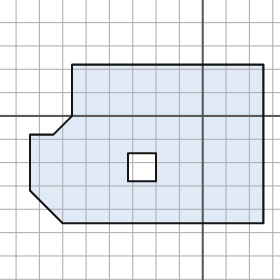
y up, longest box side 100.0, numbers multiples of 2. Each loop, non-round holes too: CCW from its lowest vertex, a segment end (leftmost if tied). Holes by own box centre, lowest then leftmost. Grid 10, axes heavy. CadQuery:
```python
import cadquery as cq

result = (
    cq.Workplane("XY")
    .moveTo(-60.0, -46.0)
    .lineTo(26.0, -46.0)
    .lineTo(26.0, 22.0)
    .lineTo(-56.0, 22.0)
    .lineTo(-56.0, 0.0)
    .lineTo(-64.0, -8.0)
    .lineTo(-74.0, -8.0)
    .lineTo(-74.0, -32.0)
    .close()
    .moveTo(-32.0, -28.0)
    .lineTo(-20.0, -28.0)
    .lineTo(-20.0, -16.0)
    .lineTo(-32.0, -16.0)
    .close()
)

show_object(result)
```